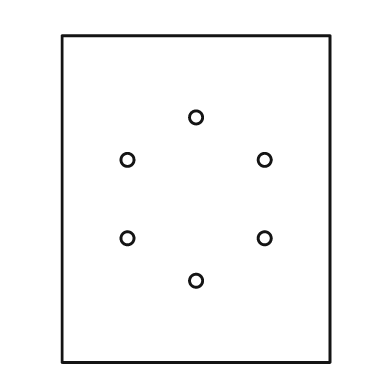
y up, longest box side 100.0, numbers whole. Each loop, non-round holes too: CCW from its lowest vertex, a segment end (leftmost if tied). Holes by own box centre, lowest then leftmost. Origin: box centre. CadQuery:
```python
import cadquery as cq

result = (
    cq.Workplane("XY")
    .moveTo(-41.0, -50.0)
    .lineTo(41.0, -50.0)
    .lineTo(41.0, 50.0)
    .lineTo(-41.0, 50.0)
    .close()
    .moveTo(0.0, -25.0)
    .circle(2.0)
    .moveTo(-21.0, -12.0)
    .circle(2.0)
    .moveTo(21.0, -12.0)
    .circle(2.0)
    .moveTo(-21.0, 12.0)
    .circle(2.0)
    .moveTo(21.0, 12.0)
    .circle(2.0)
    .moveTo(0.0, 25.0)
    .circle(2.0)
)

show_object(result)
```